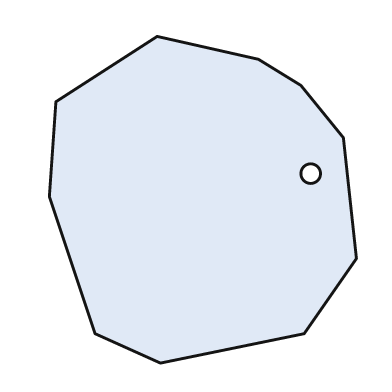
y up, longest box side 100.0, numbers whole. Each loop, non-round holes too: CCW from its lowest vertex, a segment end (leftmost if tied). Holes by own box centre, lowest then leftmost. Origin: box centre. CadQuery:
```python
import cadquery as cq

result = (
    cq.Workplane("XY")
    .moveTo(-13.0, -50.0)
    .lineTo(31.0, -41.0)
    .lineTo(47.0, -18.0)
    .lineTo(43.0, 19.0)
    .lineTo(30.0, 35.0)
    .lineTo(17.0, 43.0)
    .lineTo(-14.0, 50.0)
    .lineTo(-45.0, 30.0)
    .lineTo(-47.0, 1.0)
    .lineTo(-33.0, -41.0)
    .close()
    .moveTo(33.0, 8.0)
    .circle(3.0)
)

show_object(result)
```